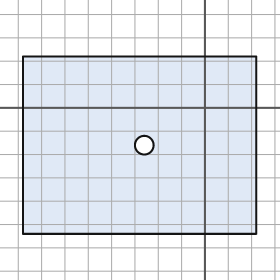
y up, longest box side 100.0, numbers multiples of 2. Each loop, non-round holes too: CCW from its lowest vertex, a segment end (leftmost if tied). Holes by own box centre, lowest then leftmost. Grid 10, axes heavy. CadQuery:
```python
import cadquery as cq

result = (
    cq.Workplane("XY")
    .moveTo(-78.0, -54.0)
    .lineTo(22.0, -54.0)
    .lineTo(22.0, 22.0)
    .lineTo(-78.0, 22.0)
    .close()
    .moveTo(-26.0, -16.0)
    .circle(4.0)
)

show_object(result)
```